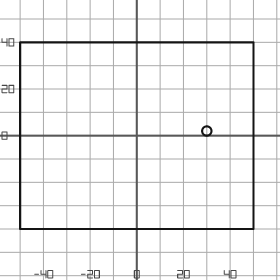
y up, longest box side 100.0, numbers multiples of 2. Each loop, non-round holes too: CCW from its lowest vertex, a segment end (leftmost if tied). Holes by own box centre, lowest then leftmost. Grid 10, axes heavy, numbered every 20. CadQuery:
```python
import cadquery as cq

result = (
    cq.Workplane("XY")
    .moveTo(-50.0, -40.0)
    .lineTo(50.0, -40.0)
    .lineTo(50.0, 40.0)
    .lineTo(-50.0, 40.0)
    .close()
    .moveTo(30.0, 2.0)
    .circle(2.0)
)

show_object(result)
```